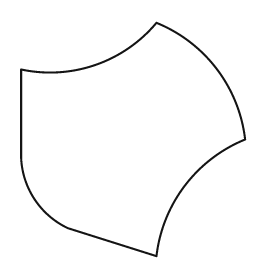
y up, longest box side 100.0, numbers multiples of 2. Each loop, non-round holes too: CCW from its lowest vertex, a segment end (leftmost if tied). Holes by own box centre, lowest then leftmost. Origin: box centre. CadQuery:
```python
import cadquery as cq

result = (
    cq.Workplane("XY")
    .moveTo(10.0, -50.0)
    .threePointArc((22.0, -20.0), (48.0, 0.0))
    .threePointArc((36.0, 30.0), (10.0, 50.0))
    .threePointArc((-16.0, 32.0), (-48.0, 30.0))
    .lineTo(-48.0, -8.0)
    .threePointArc((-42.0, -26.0), (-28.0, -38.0))
    .close()
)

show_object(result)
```